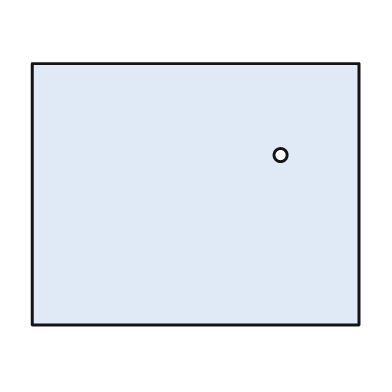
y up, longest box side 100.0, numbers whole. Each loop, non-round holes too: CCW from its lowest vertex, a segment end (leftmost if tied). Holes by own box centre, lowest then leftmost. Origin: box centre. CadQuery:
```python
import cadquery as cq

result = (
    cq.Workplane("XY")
    .moveTo(-50.0, -40.0)
    .lineTo(50.0, -40.0)
    .lineTo(50.0, 40.0)
    .lineTo(-50.0, 40.0)
    .close()
    .moveTo(26.0, 12.0)
    .circle(2.0)
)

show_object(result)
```